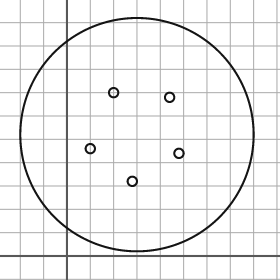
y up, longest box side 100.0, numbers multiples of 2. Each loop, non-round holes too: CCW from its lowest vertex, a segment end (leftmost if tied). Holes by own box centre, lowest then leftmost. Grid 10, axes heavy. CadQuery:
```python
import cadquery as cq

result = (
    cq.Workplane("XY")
    .moveTo(30.0, 52.0)
    .circle(50.0)
    .moveTo(28.0, 32.0)
    .circle(2.0)
    .moveTo(48.0, 44.0)
    .circle(2.0)
    .moveTo(10.0, 46.0)
    .circle(2.0)
    .moveTo(44.0, 68.0)
    .circle(2.0)
    .moveTo(20.0, 70.0)
    .circle(2.0)
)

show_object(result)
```